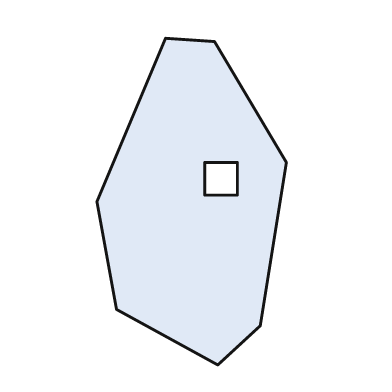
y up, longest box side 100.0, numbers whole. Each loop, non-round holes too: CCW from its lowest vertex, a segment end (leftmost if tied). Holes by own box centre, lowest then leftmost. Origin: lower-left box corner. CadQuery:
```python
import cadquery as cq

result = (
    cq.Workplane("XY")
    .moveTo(37.0, 0.0)
    .lineTo(50.0, 12.0)
    .lineTo(58.0, 62.0)
    .lineTo(36.0, 99.0)
    .lineTo(21.0, 100.0)
    .lineTo(0.0, 50.0)
    .lineTo(6.0, 17.0)
    .close()
    .moveTo(33.0, 52.0)
    .lineTo(43.0, 52.0)
    .lineTo(43.0, 62.0)
    .lineTo(33.0, 62.0)
    .close()
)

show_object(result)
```